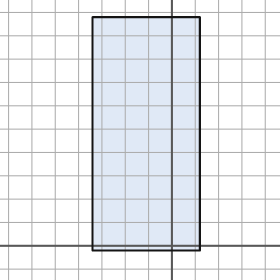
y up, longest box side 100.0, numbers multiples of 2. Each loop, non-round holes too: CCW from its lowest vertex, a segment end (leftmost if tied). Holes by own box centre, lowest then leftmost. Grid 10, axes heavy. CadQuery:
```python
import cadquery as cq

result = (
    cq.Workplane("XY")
    .moveTo(-34.0, -2.0)
    .lineTo(12.0, -2.0)
    .lineTo(12.0, 98.0)
    .lineTo(-34.0, 98.0)
    .close()
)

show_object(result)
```